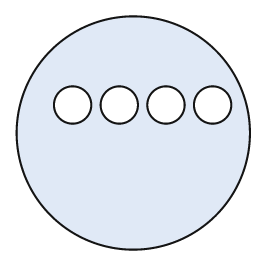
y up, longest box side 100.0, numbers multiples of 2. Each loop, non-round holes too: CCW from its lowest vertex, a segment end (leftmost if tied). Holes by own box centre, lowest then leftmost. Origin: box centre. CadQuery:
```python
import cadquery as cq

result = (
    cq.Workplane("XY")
    .moveTo(0.0, 0.0)
    .circle(50.0)
    .moveTo(-26.0, 12.0)
    .circle(8.0)
    .moveTo(-6.0, 12.0)
    .circle(8.0)
    .moveTo(14.0, 12.0)
    .circle(8.0)
    .moveTo(34.0, 12.0)
    .circle(8.0)
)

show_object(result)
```